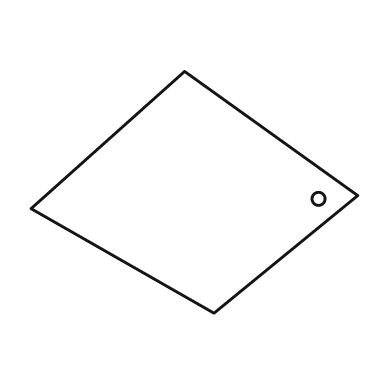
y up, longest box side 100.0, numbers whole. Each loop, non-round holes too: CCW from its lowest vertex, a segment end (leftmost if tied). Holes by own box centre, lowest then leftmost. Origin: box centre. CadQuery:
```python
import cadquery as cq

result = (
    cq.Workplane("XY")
    .moveTo(6.0, -37.0)
    .lineTo(50.0, -1.0)
    .lineTo(-3.0, 37.0)
    .lineTo(-50.0, -5.0)
    .close()
    .moveTo(38.0, -2.0)
    .circle(2.0)
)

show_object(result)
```